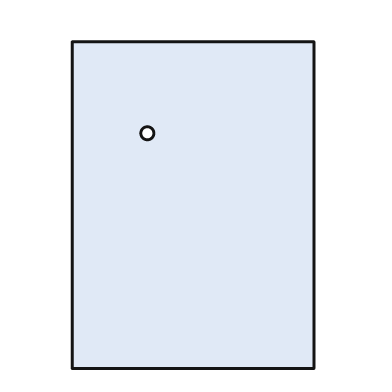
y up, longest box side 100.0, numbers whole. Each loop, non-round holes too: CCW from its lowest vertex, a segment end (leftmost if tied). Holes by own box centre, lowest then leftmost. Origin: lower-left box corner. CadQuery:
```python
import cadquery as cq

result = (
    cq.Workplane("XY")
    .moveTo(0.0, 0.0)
    .lineTo(74.0, 0.0)
    .lineTo(74.0, 100.0)
    .lineTo(0.0, 100.0)
    .close()
    .moveTo(23.0, 72.0)
    .circle(2.0)
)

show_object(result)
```